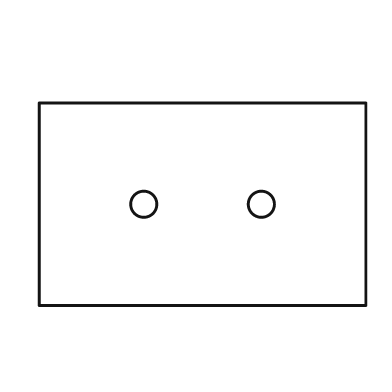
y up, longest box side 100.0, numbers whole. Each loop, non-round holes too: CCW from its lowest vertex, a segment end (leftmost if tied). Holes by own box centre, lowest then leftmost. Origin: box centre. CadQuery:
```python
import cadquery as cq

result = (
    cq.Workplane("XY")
    .moveTo(-50.0, -31.0)
    .lineTo(50.0, -31.0)
    .lineTo(50.0, 31.0)
    .lineTo(-50.0, 31.0)
    .close()
    .moveTo(-18.0, 0.0)
    .circle(4.0)
    .moveTo(18.0, 0.0)
    .circle(4.0)
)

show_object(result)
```